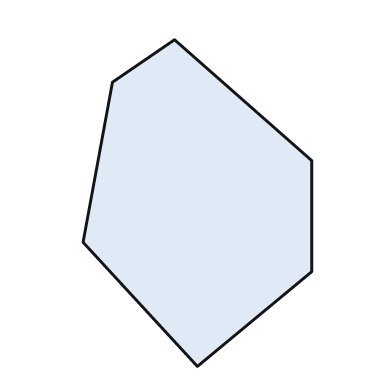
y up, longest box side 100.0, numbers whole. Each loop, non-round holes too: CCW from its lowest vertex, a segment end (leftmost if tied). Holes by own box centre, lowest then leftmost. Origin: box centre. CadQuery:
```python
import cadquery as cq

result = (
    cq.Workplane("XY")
    .moveTo(0.0, -50.0)
    .lineTo(35.0, -21.0)
    .lineTo(35.0, 13.0)
    .lineTo(-7.0, 50.0)
    .lineTo(-26.0, 37.0)
    .lineTo(-35.0, -12.0)
    .close()
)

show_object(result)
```